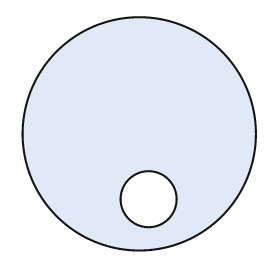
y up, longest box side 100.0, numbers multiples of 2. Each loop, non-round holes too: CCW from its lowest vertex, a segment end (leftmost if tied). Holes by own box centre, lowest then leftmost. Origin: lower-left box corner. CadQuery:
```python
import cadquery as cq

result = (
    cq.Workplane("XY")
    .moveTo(50.0, 50.0)
    .circle(50.0)
    .moveTo(54.0, 22.0)
    .circle(12.0)
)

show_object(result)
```